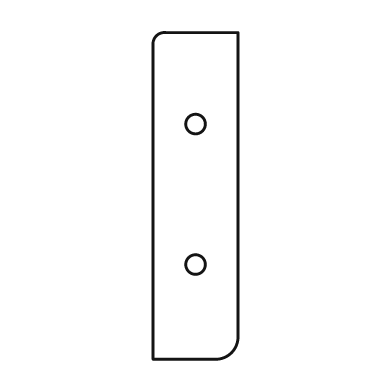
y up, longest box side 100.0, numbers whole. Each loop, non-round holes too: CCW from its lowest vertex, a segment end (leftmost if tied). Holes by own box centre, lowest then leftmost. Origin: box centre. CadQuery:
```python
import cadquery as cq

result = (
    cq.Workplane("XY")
    .moveTo(-13.0, -50.0)
    .lineTo(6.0, -50.0)
    .threePointArc((11.0, -48.0), (13.0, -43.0))
    .lineTo(13.0, 50.0)
    .lineTo(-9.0, 50.0)
    .threePointArc((-12.0, 49.0), (-13.0, 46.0))
    .close()
    .moveTo(0.0, -21.0)
    .circle(3.0)
    .moveTo(0.0, 22.0)
    .circle(3.0)
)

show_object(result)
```